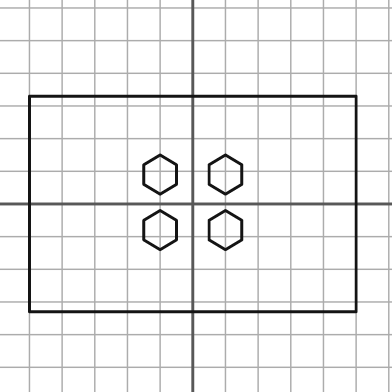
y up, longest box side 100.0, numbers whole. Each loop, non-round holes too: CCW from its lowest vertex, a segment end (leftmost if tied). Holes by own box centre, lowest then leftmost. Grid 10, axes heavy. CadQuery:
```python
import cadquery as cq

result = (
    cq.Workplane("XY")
    .moveTo(-50.0, -33.0)
    .lineTo(50.0, -33.0)
    .lineTo(50.0, 33.0)
    .lineTo(-50.0, 33.0)
    .close()
    .moveTo(-10.0, -14.0)
    .lineTo(-5.0, -11.0)
    .lineTo(-5.0, -5.0)
    .lineTo(-10.0, -2.0)
    .lineTo(-15.0, -5.0)
    .lineTo(-15.0, -11.0)
    .close()
    .moveTo(10.0, -14.0)
    .lineTo(15.0, -11.0)
    .lineTo(15.0, -5.0)
    .lineTo(10.0, -2.0)
    .lineTo(5.0, -5.0)
    .lineTo(5.0, -11.0)
    .close()
    .moveTo(-10.0, 3.0)
    .lineTo(-5.0, 6.0)
    .lineTo(-5.0, 12.0)
    .lineTo(-10.0, 15.0)
    .lineTo(-15.0, 12.0)
    .lineTo(-15.0, 6.0)
    .close()
    .moveTo(10.0, 3.0)
    .lineTo(15.0, 6.0)
    .lineTo(15.0, 12.0)
    .lineTo(10.0, 15.0)
    .lineTo(5.0, 12.0)
    .lineTo(5.0, 6.0)
    .close()
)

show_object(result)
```